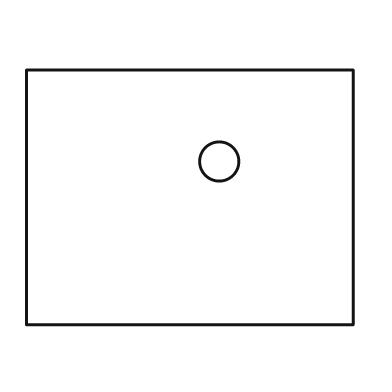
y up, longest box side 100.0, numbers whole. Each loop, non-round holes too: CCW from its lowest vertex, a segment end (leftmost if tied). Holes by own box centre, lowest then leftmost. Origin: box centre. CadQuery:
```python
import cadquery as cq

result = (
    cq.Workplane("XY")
    .moveTo(-50.0, -39.0)
    .lineTo(50.0, -39.0)
    .lineTo(50.0, 39.0)
    .lineTo(-50.0, 39.0)
    .close()
    .moveTo(9.0, 11.0)
    .circle(6.0)
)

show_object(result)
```